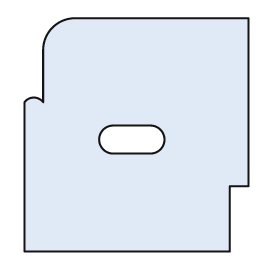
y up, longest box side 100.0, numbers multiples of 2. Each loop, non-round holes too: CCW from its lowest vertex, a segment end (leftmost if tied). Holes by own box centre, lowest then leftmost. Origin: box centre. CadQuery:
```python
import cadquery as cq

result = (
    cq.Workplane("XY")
    .moveTo(-48.0, -50.0)
    .lineTo(40.0, -50.0)
    .lineTo(40.0, -22.0)
    .lineTo(48.0, -22.0)
    .lineTo(48.0, 50.0)
    .lineTo(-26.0, 50.0)
    .threePointArc((-36.0, 46.0), (-40.0, 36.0))
    .lineTo(-40.0, 14.0)
    .threePointArc((-44.0, 16.0), (-48.0, 14.0))
    .close()
    .moveTo(-10.0, -8.0)
    .lineTo(6.0, -8.0)
    .threePointArc((12.0, -2.0), (6.0, 4.0))
    .lineTo(-10.0, 4.0)
    .threePointArc((-16.0, -2.0), (-10.0, -8.0))
    .close()
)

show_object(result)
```